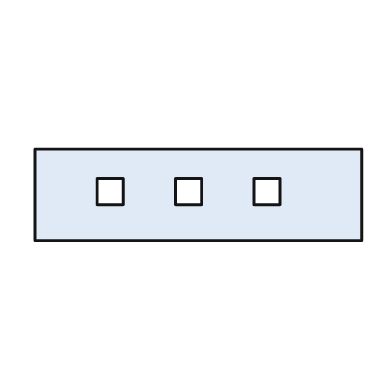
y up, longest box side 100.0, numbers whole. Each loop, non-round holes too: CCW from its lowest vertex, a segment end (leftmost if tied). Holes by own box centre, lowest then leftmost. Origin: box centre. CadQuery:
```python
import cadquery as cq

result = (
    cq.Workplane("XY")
    .moveTo(-50.0, -14.0)
    .lineTo(50.0, -14.0)
    .lineTo(50.0, 14.0)
    .lineTo(-50.0, 14.0)
    .close()
    .moveTo(-31.0, -3.0)
    .lineTo(-23.0, -3.0)
    .lineTo(-23.0, 5.0)
    .lineTo(-31.0, 5.0)
    .close()
    .moveTo(-7.0, -3.0)
    .lineTo(1.0, -3.0)
    .lineTo(1.0, 5.0)
    .lineTo(-7.0, 5.0)
    .close()
    .moveTo(17.0, -3.0)
    .lineTo(25.0, -3.0)
    .lineTo(25.0, 5.0)
    .lineTo(17.0, 5.0)
    .close()
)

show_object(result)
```